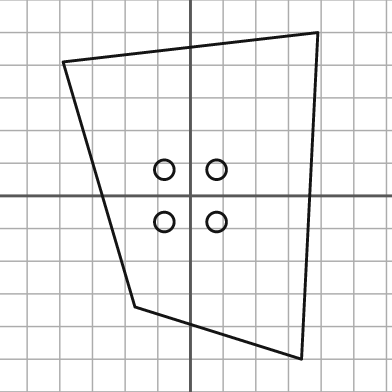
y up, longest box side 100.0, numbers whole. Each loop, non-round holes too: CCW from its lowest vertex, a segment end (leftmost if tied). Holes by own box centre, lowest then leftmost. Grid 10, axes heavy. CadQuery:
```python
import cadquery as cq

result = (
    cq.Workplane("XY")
    .moveTo(34.0, -50.0)
    .lineTo(39.0, 50.0)
    .lineTo(-39.0, 41.0)
    .lineTo(-17.0, -34.0)
    .close()
    .moveTo(-8.0, -8.0)
    .circle(3.0)
    .moveTo(8.0, -8.0)
    .circle(3.0)
    .moveTo(-8.0, 8.0)
    .circle(3.0)
    .moveTo(8.0, 8.0)
    .circle(3.0)
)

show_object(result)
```